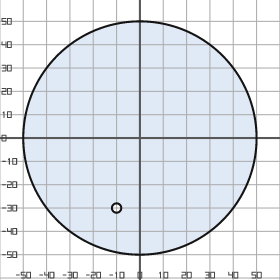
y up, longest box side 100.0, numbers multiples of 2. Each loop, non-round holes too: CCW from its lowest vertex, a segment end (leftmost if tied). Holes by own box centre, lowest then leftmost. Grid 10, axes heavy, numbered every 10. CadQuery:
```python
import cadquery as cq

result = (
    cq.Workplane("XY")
    .moveTo(0.0, 0.0)
    .circle(50.0)
    .moveTo(-10.0, -30.0)
    .circle(2.0)
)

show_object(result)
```